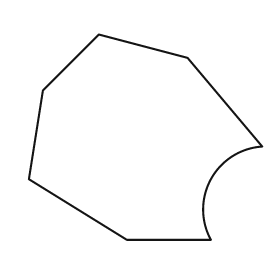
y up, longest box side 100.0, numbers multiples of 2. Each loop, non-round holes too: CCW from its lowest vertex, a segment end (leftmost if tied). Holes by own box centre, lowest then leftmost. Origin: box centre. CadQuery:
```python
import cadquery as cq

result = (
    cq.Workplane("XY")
    .moveTo(-8.0, -44.0)
    .lineTo(28.0, -44.0)
    .threePointArc((28.0, -18.0), (50.0, -4.0))
    .lineTo(18.0, 34.0)
    .lineTo(-20.0, 44.0)
    .lineTo(-44.0, 20.0)
    .lineTo(-50.0, -18.0)
    .close()
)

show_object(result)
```